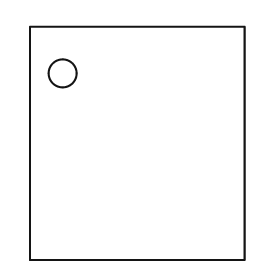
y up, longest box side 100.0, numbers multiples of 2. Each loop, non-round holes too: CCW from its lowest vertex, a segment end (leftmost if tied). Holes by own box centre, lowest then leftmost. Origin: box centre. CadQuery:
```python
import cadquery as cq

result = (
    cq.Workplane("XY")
    .moveTo(-46.0, -50.0)
    .lineTo(46.0, -50.0)
    .lineTo(46.0, 50.0)
    .lineTo(-46.0, 50.0)
    .close()
    .moveTo(-32.0, 30.0)
    .circle(6.0)
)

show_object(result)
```